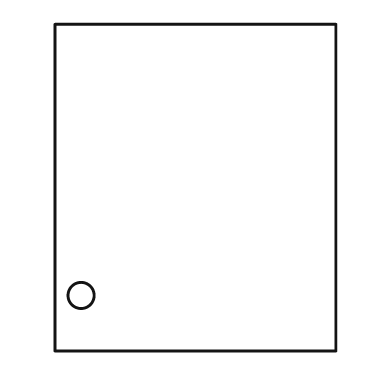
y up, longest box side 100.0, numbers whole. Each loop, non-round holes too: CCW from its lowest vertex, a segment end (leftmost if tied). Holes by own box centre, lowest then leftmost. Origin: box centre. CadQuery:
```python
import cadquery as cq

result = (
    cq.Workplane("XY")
    .moveTo(-43.0, -50.0)
    .lineTo(43.0, -50.0)
    .lineTo(43.0, 50.0)
    .lineTo(-43.0, 50.0)
    .close()
    .moveTo(-35.0, -33.0)
    .circle(4.0)
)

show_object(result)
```